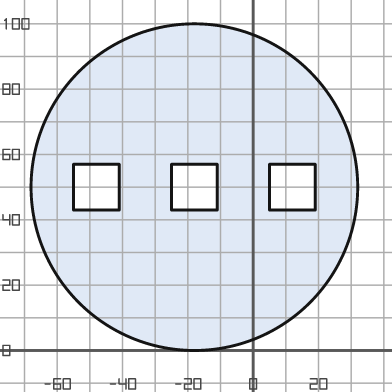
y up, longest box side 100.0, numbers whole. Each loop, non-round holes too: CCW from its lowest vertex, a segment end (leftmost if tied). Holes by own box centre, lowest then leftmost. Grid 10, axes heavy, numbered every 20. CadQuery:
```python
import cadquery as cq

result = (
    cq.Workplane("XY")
    .moveTo(-18.0, 50.0)
    .circle(50.0)
    .moveTo(-55.0, 43.0)
    .lineTo(-41.0, 43.0)
    .lineTo(-41.0, 57.0)
    .lineTo(-55.0, 57.0)
    .close()
    .moveTo(-25.0, 43.0)
    .lineTo(-11.0, 43.0)
    .lineTo(-11.0, 57.0)
    .lineTo(-25.0, 57.0)
    .close()
    .moveTo(5.0, 43.0)
    .lineTo(19.0, 43.0)
    .lineTo(19.0, 57.0)
    .lineTo(5.0, 57.0)
    .close()
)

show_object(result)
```